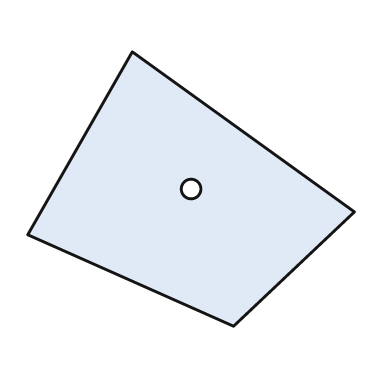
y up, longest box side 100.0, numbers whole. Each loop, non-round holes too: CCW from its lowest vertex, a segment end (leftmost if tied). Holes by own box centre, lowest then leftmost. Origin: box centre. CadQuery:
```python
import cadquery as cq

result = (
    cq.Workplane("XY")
    .moveTo(13.0, -42.0)
    .lineTo(50.0, -7.0)
    .lineTo(-18.0, 42.0)
    .lineTo(-50.0, -14.0)
    .close()
    .moveTo(0.0, 0.0)
    .circle(3.0)
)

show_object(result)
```